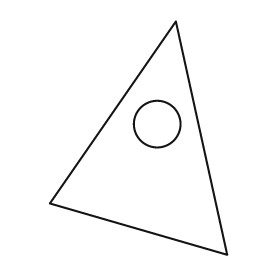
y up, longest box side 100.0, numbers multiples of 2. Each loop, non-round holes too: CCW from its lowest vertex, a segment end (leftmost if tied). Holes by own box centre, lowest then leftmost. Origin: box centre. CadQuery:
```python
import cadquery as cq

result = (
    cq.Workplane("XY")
    .moveTo(38.0, -50.0)
    .lineTo(16.0, 50.0)
    .lineTo(-38.0, -28.0)
    .close()
    .moveTo(8.0, 6.0)
    .circle(10.0)
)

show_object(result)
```